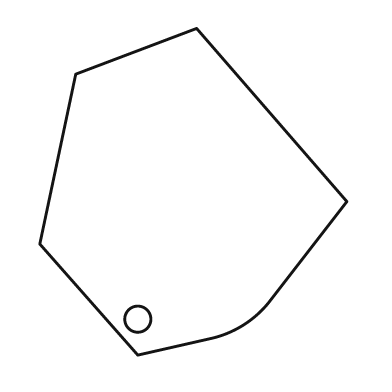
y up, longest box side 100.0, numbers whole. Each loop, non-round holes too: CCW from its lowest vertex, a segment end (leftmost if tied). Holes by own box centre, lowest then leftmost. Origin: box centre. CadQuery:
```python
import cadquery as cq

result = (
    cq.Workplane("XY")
    .moveTo(-17.0, -50.0)
    .lineTo(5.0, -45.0)
    .threePointArc((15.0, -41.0), (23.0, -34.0))
    .lineTo(47.0, -3.0)
    .lineTo(1.0, 50.0)
    .lineTo(-36.0, 36.0)
    .lineTo(-47.0, -16.0)
    .close()
    .moveTo(-17.0, -39.0)
    .circle(4.0)
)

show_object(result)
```